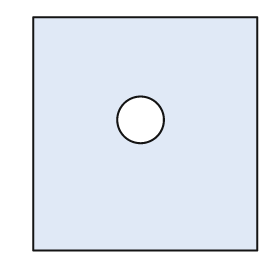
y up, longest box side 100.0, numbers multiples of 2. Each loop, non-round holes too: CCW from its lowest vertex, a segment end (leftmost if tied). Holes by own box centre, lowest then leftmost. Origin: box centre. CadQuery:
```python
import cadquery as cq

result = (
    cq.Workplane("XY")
    .moveTo(-48.0, -50.0)
    .lineTo(48.0, -50.0)
    .lineTo(48.0, 50.0)
    .lineTo(-48.0, 50.0)
    .close()
    .moveTo(-2.0, 6.0)
    .circle(10.0)
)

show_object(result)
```